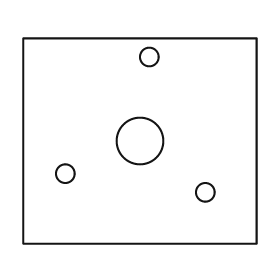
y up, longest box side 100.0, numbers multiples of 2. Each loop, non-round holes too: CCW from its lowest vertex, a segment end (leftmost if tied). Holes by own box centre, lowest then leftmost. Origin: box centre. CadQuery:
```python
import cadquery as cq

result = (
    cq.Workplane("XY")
    .moveTo(-50.0, -44.0)
    .lineTo(50.0, -44.0)
    .lineTo(50.0, 44.0)
    .lineTo(-50.0, 44.0)
    .close()
    .moveTo(28.0, -22.0)
    .circle(4.0)
    .moveTo(-32.0, -14.0)
    .circle(4.0)
    .moveTo(0.0, 0.0)
    .circle(10.0)
    .moveTo(4.0, 36.0)
    .circle(4.0)
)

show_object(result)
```